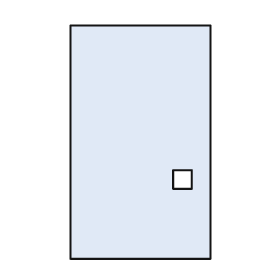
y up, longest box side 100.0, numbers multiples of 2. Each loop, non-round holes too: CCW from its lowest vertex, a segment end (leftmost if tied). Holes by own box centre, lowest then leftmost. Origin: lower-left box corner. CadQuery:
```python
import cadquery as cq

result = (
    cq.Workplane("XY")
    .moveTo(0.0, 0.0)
    .lineTo(60.0, 0.0)
    .lineTo(60.0, 100.0)
    .lineTo(0.0, 100.0)
    .close()
    .moveTo(44.0, 30.0)
    .lineTo(52.0, 30.0)
    .lineTo(52.0, 38.0)
    .lineTo(44.0, 38.0)
    .close()
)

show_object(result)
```